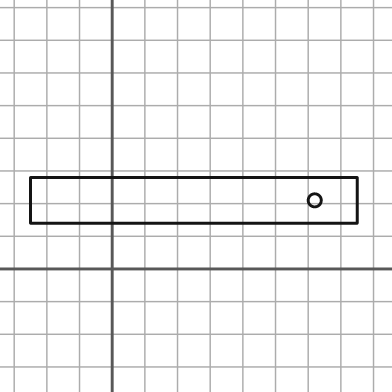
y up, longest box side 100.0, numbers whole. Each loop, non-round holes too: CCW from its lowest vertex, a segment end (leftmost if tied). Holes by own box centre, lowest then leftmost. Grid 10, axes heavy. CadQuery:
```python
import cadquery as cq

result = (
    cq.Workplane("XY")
    .moveTo(-25.0, 14.0)
    .lineTo(75.0, 14.0)
    .lineTo(75.0, 28.0)
    .lineTo(-25.0, 28.0)
    .close()
    .moveTo(62.0, 21.0)
    .circle(2.0)
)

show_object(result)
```